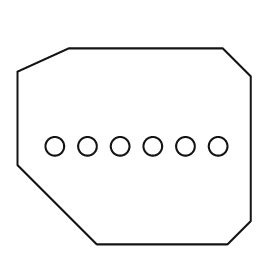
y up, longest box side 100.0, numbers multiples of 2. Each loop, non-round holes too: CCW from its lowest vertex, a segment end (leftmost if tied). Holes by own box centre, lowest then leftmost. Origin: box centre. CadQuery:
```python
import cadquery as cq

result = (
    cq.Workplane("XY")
    .moveTo(-16.0, -42.0)
    .lineTo(40.0, -42.0)
    .lineTo(50.0, -32.0)
    .lineTo(50.0, 30.0)
    .lineTo(38.0, 42.0)
    .lineTo(-28.0, 42.0)
    .lineTo(-50.0, 32.0)
    .lineTo(-50.0, -8.0)
    .close()
    .moveTo(-34.0, 0.0)
    .circle(4.0)
    .moveTo(-20.0, 0.0)
    .circle(4.0)
    .moveTo(-6.0, 0.0)
    .circle(4.0)
    .moveTo(8.0, 0.0)
    .circle(4.0)
    .moveTo(22.0, 0.0)
    .circle(4.0)
    .moveTo(36.0, 0.0)
    .circle(4.0)
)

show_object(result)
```